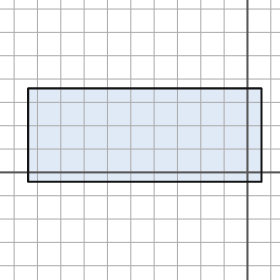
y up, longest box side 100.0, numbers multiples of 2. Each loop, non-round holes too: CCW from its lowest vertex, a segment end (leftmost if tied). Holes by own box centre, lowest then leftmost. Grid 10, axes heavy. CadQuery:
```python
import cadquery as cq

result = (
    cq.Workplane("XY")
    .moveTo(-94.0, -4.0)
    .lineTo(6.0, -4.0)
    .lineTo(6.0, 36.0)
    .lineTo(-94.0, 36.0)
    .close()
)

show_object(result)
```